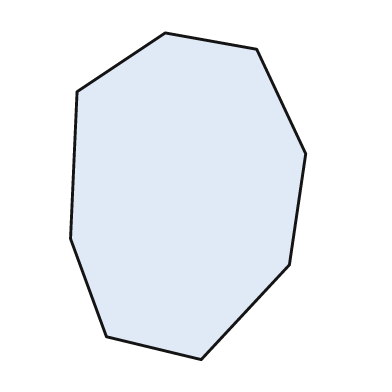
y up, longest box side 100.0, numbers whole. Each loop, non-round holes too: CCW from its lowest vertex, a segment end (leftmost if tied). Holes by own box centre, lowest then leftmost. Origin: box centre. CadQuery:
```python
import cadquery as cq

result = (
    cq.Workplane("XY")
    .moveTo(4.0, -50.0)
    .lineTo(31.0, -21.0)
    .lineTo(36.0, 13.0)
    .lineTo(21.0, 45.0)
    .lineTo(-7.0, 50.0)
    .lineTo(-34.0, 32.0)
    .lineTo(-36.0, -13.0)
    .lineTo(-25.0, -43.0)
    .close()
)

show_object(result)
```